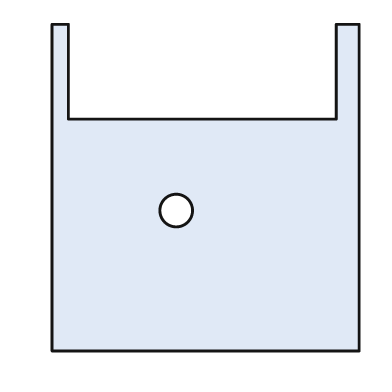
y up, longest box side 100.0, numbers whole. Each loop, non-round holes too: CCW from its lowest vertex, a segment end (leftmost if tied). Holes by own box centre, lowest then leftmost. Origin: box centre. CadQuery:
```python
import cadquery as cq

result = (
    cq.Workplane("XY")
    .moveTo(-47.0, -50.0)
    .lineTo(47.0, -50.0)
    .lineTo(47.0, 50.0)
    .lineTo(40.0, 50.0)
    .lineTo(40.0, 21.0)
    .lineTo(-42.0, 21.0)
    .lineTo(-42.0, 50.0)
    .lineTo(-47.0, 50.0)
    .close()
    .moveTo(-9.0, -7.0)
    .circle(5.0)
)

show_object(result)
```